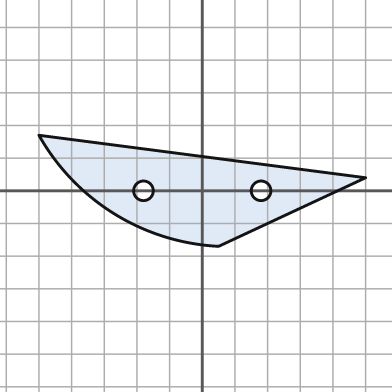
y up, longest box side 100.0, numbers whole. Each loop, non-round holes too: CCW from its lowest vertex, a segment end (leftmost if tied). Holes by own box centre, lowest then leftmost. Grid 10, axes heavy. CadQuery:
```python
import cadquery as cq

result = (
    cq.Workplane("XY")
    .moveTo(5.0, -17.0)
    .lineTo(50.0, 4.0)
    .lineTo(-50.0, 17.0)
    .threePointArc((-27.0, -7.0), (5.0, -17.0))
    .close()
    .moveTo(-18.0, 0.0)
    .circle(3.0)
    .moveTo(18.0, 0.0)
    .circle(3.0)
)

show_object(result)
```